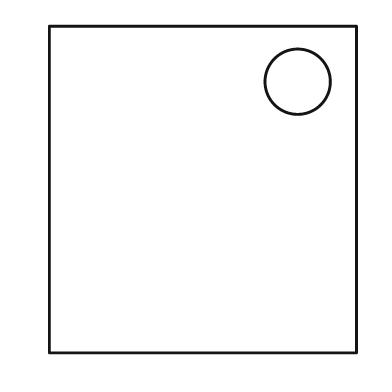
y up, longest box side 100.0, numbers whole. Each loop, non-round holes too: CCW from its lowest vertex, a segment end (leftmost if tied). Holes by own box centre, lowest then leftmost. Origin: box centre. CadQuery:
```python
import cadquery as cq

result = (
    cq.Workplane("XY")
    .moveTo(-47.0, -50.0)
    .lineTo(47.0, -50.0)
    .lineTo(47.0, 50.0)
    .lineTo(-47.0, 50.0)
    .close()
    .moveTo(29.0, 33.0)
    .circle(10.0)
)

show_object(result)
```